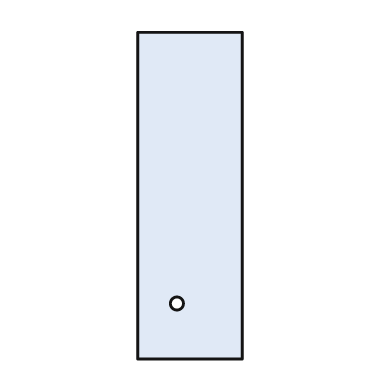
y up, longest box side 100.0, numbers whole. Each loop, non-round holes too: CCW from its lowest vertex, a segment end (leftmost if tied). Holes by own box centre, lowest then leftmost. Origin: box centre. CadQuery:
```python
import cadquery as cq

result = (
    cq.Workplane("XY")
    .moveTo(-16.0, -50.0)
    .lineTo(16.0, -50.0)
    .lineTo(16.0, 50.0)
    .lineTo(-16.0, 50.0)
    .close()
    .moveTo(-4.0, -33.0)
    .circle(2.0)
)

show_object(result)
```